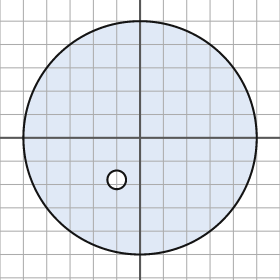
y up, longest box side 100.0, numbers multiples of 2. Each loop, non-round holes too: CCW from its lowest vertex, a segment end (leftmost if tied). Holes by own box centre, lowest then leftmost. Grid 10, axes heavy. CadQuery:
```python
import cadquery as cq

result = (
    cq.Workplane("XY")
    .moveTo(0.0, 0.0)
    .circle(50.0)
    .moveTo(-10.0, -18.0)
    .circle(4.0)
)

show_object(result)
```